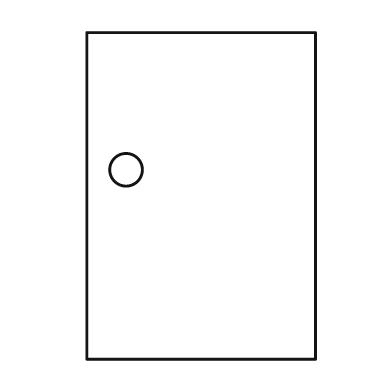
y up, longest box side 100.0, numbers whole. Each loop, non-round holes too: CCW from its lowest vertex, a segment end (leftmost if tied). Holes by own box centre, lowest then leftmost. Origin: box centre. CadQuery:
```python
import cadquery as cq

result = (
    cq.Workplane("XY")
    .moveTo(-35.0, -50.0)
    .lineTo(35.0, -50.0)
    .lineTo(35.0, 50.0)
    .lineTo(-35.0, 50.0)
    .close()
    .moveTo(-23.0, 8.0)
    .circle(5.0)
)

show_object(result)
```